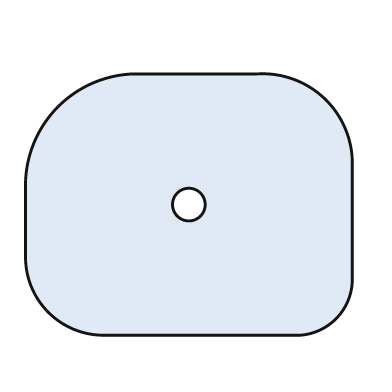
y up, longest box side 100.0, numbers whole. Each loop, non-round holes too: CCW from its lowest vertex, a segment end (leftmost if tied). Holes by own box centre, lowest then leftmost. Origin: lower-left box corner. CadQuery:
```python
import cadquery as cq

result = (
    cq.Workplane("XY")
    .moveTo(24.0, 0.0)
    .lineTo(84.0, 0.0)
    .threePointArc((95.0, 5.0), (100.0, 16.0))
    .lineTo(100.0, 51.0)
    .threePointArc((92.0, 72.0), (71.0, 80.0))
    .lineTo(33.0, 80.0)
    .threePointArc((10.0, 70.0), (0.0, 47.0))
    .lineTo(0.0, 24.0)
    .threePointArc((7.0, 7.0), (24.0, 0.0))
    .close()
    .moveTo(50.0, 40.0)
    .circle(5.0)
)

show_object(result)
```